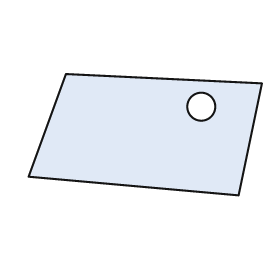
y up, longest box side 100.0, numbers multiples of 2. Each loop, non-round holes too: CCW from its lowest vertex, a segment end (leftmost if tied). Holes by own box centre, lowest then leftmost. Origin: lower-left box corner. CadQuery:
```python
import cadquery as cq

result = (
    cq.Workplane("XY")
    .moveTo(90.0, 0.0)
    .lineTo(100.0, 48.0)
    .lineTo(16.0, 52.0)
    .lineTo(0.0, 8.0)
    .close()
    .moveTo(74.0, 38.0)
    .circle(6.0)
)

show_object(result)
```